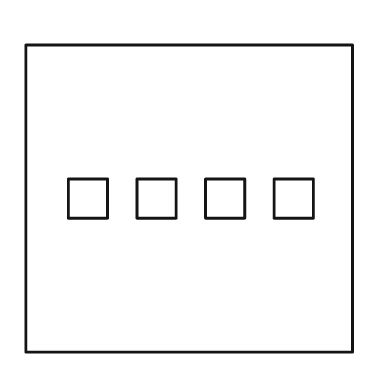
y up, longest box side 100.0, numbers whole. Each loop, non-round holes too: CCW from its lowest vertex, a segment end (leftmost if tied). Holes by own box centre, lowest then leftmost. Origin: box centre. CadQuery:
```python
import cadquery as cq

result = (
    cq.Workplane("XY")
    .moveTo(-50.0, -47.0)
    .lineTo(50.0, -47.0)
    .lineTo(50.0, 47.0)
    .lineTo(-50.0, 47.0)
    .close()
    .moveTo(-37.0, -6.0)
    .lineTo(-25.0, -6.0)
    .lineTo(-25.0, 6.0)
    .lineTo(-37.0, 6.0)
    .close()
    .moveTo(-16.0, -6.0)
    .lineTo(-4.0, -6.0)
    .lineTo(-4.0, 6.0)
    .lineTo(-16.0, 6.0)
    .close()
    .moveTo(5.0, -6.0)
    .lineTo(17.0, -6.0)
    .lineTo(17.0, 6.0)
    .lineTo(5.0, 6.0)
    .close()
    .moveTo(26.0, -6.0)
    .lineTo(38.0, -6.0)
    .lineTo(38.0, 6.0)
    .lineTo(26.0, 6.0)
    .close()
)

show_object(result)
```